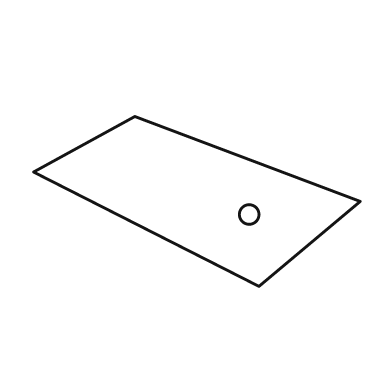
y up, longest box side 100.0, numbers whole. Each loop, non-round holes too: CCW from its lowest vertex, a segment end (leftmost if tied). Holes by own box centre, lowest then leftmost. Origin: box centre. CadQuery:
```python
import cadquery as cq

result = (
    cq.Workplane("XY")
    .moveTo(19.0, -26.0)
    .lineTo(50.0, 0.0)
    .lineTo(-19.0, 26.0)
    .lineTo(-50.0, 9.0)
    .close()
    .moveTo(16.0, -4.0)
    .circle(3.0)
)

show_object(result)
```